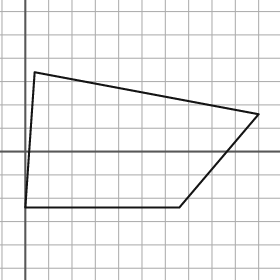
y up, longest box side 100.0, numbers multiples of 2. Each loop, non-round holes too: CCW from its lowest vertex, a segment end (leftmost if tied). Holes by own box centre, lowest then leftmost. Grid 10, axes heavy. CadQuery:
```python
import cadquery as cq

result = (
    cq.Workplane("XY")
    .moveTo(0.0, -24.0)
    .lineTo(66.0, -24.0)
    .lineTo(100.0, 16.0)
    .lineTo(4.0, 34.0)
    .close()
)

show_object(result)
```